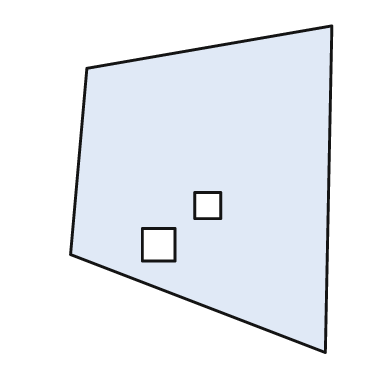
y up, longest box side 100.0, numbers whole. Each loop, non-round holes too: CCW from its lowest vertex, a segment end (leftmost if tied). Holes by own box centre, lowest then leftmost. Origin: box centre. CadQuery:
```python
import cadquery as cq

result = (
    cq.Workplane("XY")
    .moveTo(38.0, -50.0)
    .lineTo(40.0, 50.0)
    .lineTo(-35.0, 37.0)
    .lineTo(-40.0, -20.0)
    .close()
    .moveTo(-18.0, -22.0)
    .lineTo(-8.0, -22.0)
    .lineTo(-8.0, -12.0)
    .lineTo(-18.0, -12.0)
    .close()
    .moveTo(-2.0, -9.0)
    .lineTo(6.0, -9.0)
    .lineTo(6.0, -1.0)
    .lineTo(-2.0, -1.0)
    .close()
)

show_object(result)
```